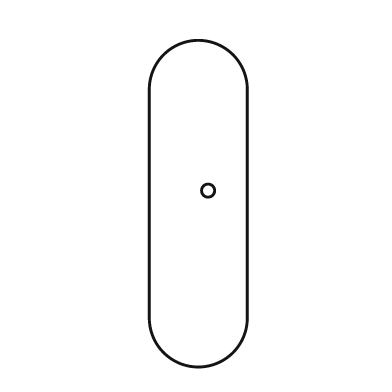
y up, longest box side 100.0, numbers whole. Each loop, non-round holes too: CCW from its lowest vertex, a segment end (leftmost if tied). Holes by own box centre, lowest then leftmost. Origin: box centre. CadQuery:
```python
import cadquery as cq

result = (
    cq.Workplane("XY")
    .moveTo(-15.0, -35.0)
    .threePointArc((0.0, -50.0), (15.0, -35.0))
    .lineTo(15.0, 35.0)
    .threePointArc((0.0, 50.0), (-15.0, 35.0))
    .close()
    .moveTo(3.0, 4.0)
    .circle(2.0)
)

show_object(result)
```